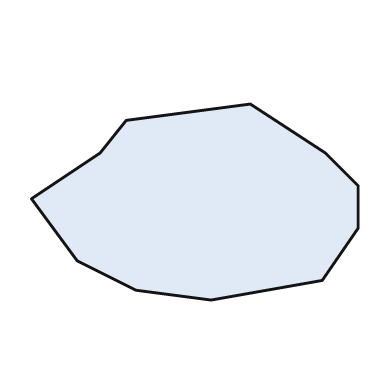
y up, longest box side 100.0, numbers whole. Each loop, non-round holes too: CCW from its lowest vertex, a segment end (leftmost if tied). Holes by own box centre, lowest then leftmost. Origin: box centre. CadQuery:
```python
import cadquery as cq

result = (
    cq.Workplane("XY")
    .moveTo(5.0, -30.0)
    .lineTo(39.0, -24.0)
    .lineTo(50.0, -8.0)
    .lineTo(50.0, 5.0)
    .lineTo(40.0, 15.0)
    .lineTo(17.0, 30.0)
    .lineTo(-21.0, 25.0)
    .lineTo(-29.0, 15.0)
    .lineTo(-50.0, 1.0)
    .lineTo(-36.0, -18.0)
    .lineTo(-18.0, -27.0)
    .close()
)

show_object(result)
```